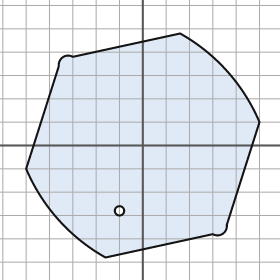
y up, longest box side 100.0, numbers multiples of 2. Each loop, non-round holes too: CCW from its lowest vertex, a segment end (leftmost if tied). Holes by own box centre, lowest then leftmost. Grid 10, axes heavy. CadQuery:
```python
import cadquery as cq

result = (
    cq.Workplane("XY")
    .moveTo(-16.0, -48.0)
    .lineTo(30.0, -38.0)
    .threePointArc((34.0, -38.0), (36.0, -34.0))
    .lineTo(50.0, 10.0)
    .threePointArc((36.0, 32.0), (16.0, 48.0))
    .lineTo(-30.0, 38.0)
    .threePointArc((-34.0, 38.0), (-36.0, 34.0))
    .lineTo(-50.0, -10.0)
    .threePointArc((-36.0, -32.0), (-16.0, -48.0))
    .close()
    .moveTo(-10.0, -28.0)
    .circle(2.0)
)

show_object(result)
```